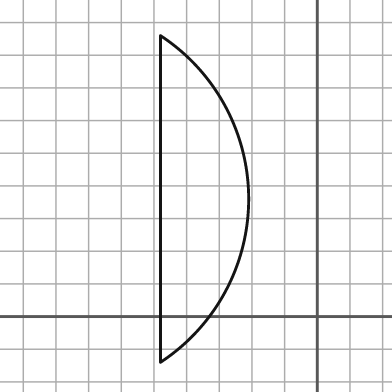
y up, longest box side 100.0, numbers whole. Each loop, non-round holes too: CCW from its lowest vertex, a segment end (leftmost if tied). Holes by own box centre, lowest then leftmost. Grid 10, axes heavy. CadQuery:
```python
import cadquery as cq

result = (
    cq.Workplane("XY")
    .moveTo(-48.0, -14.0)
    .threePointArc((-21.0, 36.0), (-48.0, 86.0))
    .close()
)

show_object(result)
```